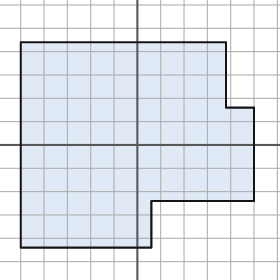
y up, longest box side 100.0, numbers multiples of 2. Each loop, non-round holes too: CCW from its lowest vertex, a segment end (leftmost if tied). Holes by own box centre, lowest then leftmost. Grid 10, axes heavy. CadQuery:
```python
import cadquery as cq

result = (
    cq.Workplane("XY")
    .moveTo(-50.0, -44.0)
    .lineTo(6.0, -44.0)
    .lineTo(6.0, -24.0)
    .lineTo(50.0, -24.0)
    .lineTo(50.0, 16.0)
    .lineTo(38.0, 16.0)
    .lineTo(38.0, 44.0)
    .lineTo(-50.0, 44.0)
    .close()
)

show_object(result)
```